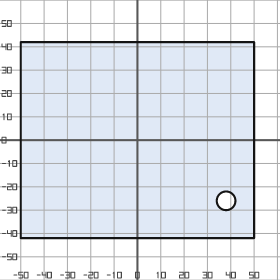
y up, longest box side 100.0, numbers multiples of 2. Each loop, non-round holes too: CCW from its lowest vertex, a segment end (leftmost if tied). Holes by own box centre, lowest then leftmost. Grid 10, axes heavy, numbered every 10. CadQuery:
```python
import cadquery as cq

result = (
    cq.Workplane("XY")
    .moveTo(-50.0, -42.0)
    .lineTo(50.0, -42.0)
    .lineTo(50.0, 42.0)
    .lineTo(-50.0, 42.0)
    .close()
    .moveTo(38.0, -26.0)
    .circle(4.0)
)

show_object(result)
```